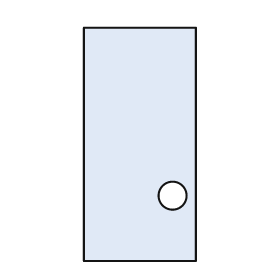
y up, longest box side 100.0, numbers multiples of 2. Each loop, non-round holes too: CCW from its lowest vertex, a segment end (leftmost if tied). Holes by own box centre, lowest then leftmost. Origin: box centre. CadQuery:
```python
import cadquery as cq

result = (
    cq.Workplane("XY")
    .moveTo(-24.0, -50.0)
    .lineTo(24.0, -50.0)
    .lineTo(24.0, 50.0)
    .lineTo(-24.0, 50.0)
    .close()
    .moveTo(14.0, -22.0)
    .circle(6.0)
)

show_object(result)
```